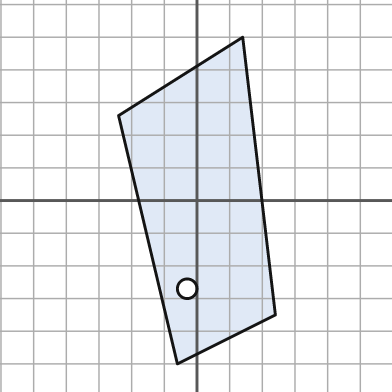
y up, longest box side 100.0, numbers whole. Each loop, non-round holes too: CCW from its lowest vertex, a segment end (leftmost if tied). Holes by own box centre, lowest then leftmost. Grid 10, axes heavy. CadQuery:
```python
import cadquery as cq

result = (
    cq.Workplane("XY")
    .moveTo(-6.0, -50.0)
    .lineTo(24.0, -35.0)
    .lineTo(14.0, 50.0)
    .lineTo(-24.0, 26.0)
    .close()
    .moveTo(-3.0, -27.0)
    .circle(3.0)
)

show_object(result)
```